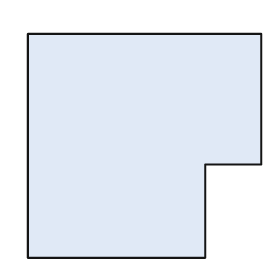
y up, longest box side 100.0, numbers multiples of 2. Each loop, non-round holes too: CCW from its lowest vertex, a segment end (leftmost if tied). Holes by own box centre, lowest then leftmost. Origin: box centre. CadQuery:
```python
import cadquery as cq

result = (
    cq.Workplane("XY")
    .moveTo(-50.0, -48.0)
    .lineTo(26.0, -48.0)
    .lineTo(26.0, -8.0)
    .lineTo(50.0, -8.0)
    .lineTo(50.0, 48.0)
    .lineTo(-50.0, 48.0)
    .close()
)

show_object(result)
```